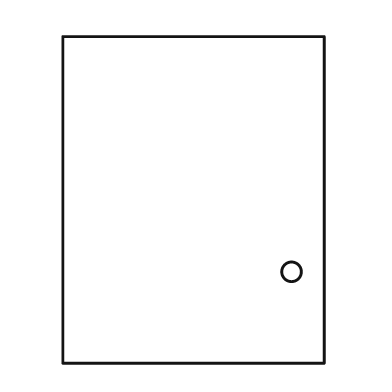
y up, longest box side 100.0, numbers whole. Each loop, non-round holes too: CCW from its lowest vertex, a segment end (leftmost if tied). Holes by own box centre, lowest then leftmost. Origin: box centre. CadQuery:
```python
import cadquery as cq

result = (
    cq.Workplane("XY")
    .moveTo(-40.0, -50.0)
    .lineTo(40.0, -50.0)
    .lineTo(40.0, 50.0)
    .lineTo(-40.0, 50.0)
    .close()
    .moveTo(30.0, -22.0)
    .circle(3.0)
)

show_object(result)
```